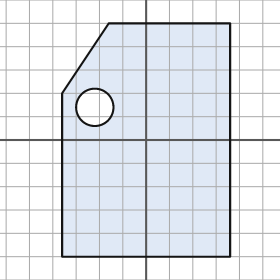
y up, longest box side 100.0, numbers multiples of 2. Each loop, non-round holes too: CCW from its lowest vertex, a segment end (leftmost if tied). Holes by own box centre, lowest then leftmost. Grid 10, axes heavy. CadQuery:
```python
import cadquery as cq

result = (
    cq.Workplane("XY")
    .moveTo(-36.0, -50.0)
    .lineTo(36.0, -50.0)
    .lineTo(36.0, 50.0)
    .lineTo(-16.0, 50.0)
    .lineTo(-36.0, 20.0)
    .close()
    .moveTo(-22.0, 14.0)
    .circle(8.0)
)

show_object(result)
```